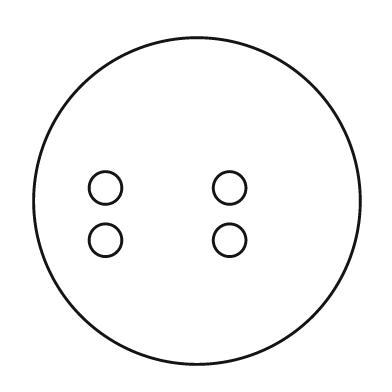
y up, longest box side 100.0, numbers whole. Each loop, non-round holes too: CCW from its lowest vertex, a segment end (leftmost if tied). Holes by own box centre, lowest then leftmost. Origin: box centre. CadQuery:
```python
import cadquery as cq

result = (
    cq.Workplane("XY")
    .moveTo(0.0, 0.0)
    .circle(50.0)
    .moveTo(-28.0, -12.0)
    .circle(5.0)
    .moveTo(10.0, -12.0)
    .circle(5.0)
    .moveTo(-28.0, 4.0)
    .circle(5.0)
    .moveTo(10.0, 4.0)
    .circle(5.0)
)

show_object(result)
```